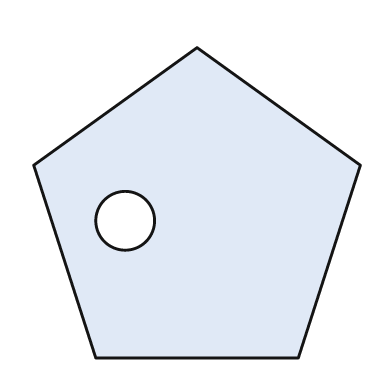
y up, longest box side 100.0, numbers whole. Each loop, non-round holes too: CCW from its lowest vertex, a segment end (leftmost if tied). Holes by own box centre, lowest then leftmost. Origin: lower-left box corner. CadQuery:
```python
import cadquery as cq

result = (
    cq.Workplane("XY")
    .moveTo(19.0, 0.0)
    .lineTo(81.0, 0.0)
    .lineTo(100.0, 59.0)
    .lineTo(50.0, 95.0)
    .lineTo(0.0, 59.0)
    .close()
    .moveTo(28.0, 42.0)
    .circle(9.0)
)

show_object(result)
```